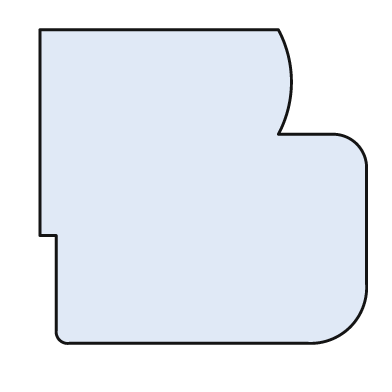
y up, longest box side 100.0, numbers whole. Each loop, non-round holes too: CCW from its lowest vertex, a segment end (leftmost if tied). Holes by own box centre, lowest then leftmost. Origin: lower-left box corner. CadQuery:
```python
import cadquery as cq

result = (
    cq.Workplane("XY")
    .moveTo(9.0, 0.0)
    .lineTo(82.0, 0.0)
    .threePointArc((95.0, 5.0), (100.0, 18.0))
    .lineTo(100.0, 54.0)
    .threePointArc((97.0, 61.0), (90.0, 64.0))
    .lineTo(73.0, 64.0)
    .threePointArc((77.0, 80.0), (73.0, 96.0))
    .lineTo(0.0, 96.0)
    .lineTo(0.0, 33.0)
    .lineTo(5.0, 33.0)
    .lineTo(5.0, 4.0)
    .threePointArc((6.0, 1.0), (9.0, 0.0))
    .close()
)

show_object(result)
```